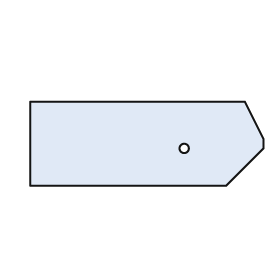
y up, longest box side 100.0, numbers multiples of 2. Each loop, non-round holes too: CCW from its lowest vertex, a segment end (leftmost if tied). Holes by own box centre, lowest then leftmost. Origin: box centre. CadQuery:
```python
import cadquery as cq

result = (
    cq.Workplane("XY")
    .moveTo(-50.0, -18.0)
    .lineTo(34.0, -18.0)
    .lineTo(50.0, -2.0)
    .lineTo(50.0, 2.0)
    .lineTo(42.0, 18.0)
    .lineTo(-50.0, 18.0)
    .close()
    .moveTo(16.0, -2.0)
    .circle(2.0)
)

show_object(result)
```